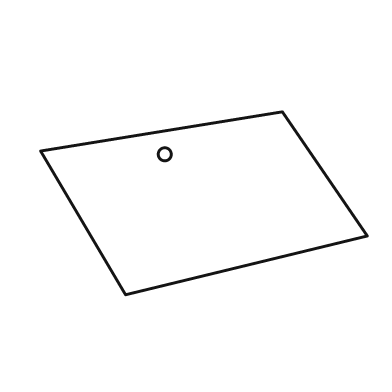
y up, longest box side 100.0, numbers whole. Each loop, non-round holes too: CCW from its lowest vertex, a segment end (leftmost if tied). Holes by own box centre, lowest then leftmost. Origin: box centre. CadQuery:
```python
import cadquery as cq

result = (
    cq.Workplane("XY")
    .moveTo(-24.0, -28.0)
    .lineTo(50.0, -10.0)
    .lineTo(24.0, 28.0)
    .lineTo(-50.0, 16.0)
    .close()
    .moveTo(-12.0, 15.0)
    .circle(2.0)
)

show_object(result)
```